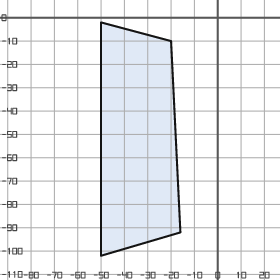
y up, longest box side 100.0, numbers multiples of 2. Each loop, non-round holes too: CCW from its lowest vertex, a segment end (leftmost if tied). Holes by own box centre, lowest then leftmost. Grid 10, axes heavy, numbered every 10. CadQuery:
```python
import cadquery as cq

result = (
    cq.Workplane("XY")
    .moveTo(-50.0, -102.0)
    .lineTo(-16.0, -92.0)
    .lineTo(-20.0, -10.0)
    .lineTo(-50.0, -2.0)
    .close()
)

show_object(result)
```